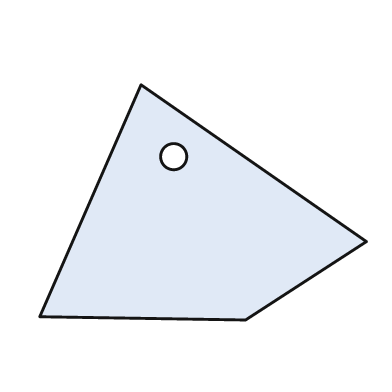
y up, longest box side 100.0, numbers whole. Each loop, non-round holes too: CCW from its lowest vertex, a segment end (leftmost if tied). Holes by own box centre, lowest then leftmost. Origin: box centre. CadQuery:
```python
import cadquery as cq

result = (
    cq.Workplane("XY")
    .moveTo(13.0, -36.0)
    .lineTo(50.0, -12.0)
    .lineTo(-19.0, 36.0)
    .lineTo(-50.0, -35.0)
    .close()
    .moveTo(-9.0, 14.0)
    .circle(4.0)
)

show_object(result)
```